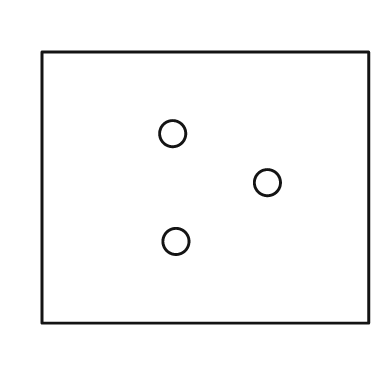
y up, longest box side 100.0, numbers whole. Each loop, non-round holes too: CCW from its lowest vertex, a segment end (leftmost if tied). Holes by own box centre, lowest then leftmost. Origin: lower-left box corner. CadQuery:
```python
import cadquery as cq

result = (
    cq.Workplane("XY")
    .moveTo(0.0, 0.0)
    .lineTo(100.0, 0.0)
    .lineTo(100.0, 83.0)
    .lineTo(0.0, 83.0)
    .close()
    .moveTo(41.0, 25.0)
    .circle(4.0)
    .moveTo(69.0, 43.0)
    .circle(4.0)
    .moveTo(40.0, 58.0)
    .circle(4.0)
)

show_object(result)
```